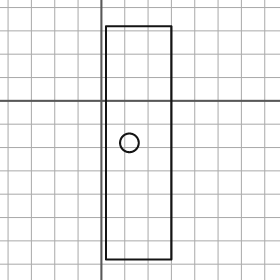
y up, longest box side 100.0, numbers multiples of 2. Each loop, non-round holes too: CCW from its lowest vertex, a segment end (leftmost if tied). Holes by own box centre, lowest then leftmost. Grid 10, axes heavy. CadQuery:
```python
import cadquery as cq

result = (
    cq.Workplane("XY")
    .moveTo(2.0, -68.0)
    .lineTo(30.0, -68.0)
    .lineTo(30.0, 32.0)
    .lineTo(2.0, 32.0)
    .close()
    .moveTo(12.0, -18.0)
    .circle(4.0)
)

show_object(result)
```